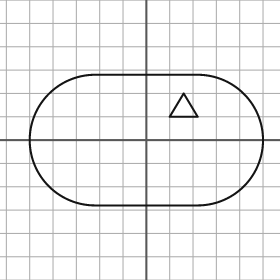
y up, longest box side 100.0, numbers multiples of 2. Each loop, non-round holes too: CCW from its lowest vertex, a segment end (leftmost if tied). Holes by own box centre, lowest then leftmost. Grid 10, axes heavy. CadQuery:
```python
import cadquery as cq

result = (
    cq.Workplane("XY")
    .moveTo(-22.0, -28.0)
    .lineTo(22.0, -28.0)
    .threePointArc((50.0, 0.0), (22.0, 28.0))
    .lineTo(-22.0, 28.0)
    .threePointArc((-50.0, 0.0), (-22.0, -28.0))
    .close()
    .moveTo(10.0, 10.0)
    .lineTo(22.0, 10.0)
    .lineTo(16.0, 20.0)
    .close()
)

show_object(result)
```